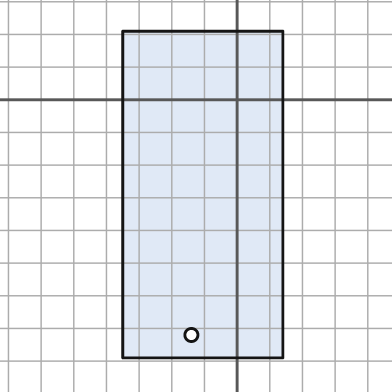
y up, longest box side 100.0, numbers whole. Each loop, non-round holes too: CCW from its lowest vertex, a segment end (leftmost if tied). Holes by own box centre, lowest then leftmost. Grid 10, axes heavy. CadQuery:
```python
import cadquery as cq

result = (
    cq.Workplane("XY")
    .moveTo(-35.0, -79.0)
    .lineTo(14.0, -79.0)
    .lineTo(14.0, 21.0)
    .lineTo(-35.0, 21.0)
    .close()
    .moveTo(-14.0, -72.0)
    .circle(2.0)
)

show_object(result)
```